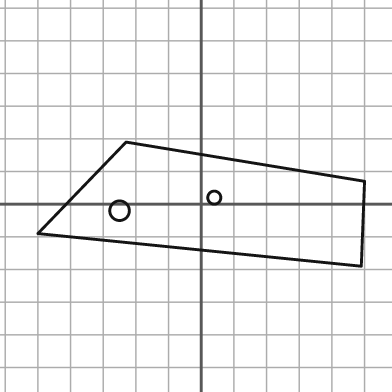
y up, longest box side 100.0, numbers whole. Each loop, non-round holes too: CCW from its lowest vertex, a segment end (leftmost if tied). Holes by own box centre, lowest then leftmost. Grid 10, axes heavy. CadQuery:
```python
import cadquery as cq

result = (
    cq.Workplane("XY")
    .moveTo(49.0, -19.0)
    .lineTo(50.0, 7.0)
    .lineTo(-23.0, 19.0)
    .lineTo(-50.0, -9.0)
    .close()
    .moveTo(-25.0, -2.0)
    .circle(3.0)
    .moveTo(4.0, 2.0)
    .circle(2.0)
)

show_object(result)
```